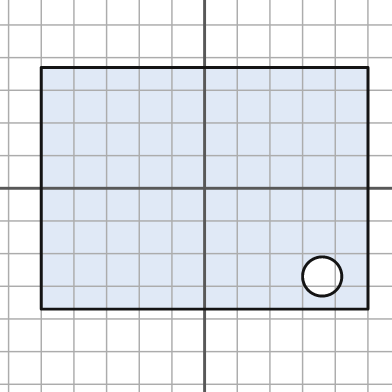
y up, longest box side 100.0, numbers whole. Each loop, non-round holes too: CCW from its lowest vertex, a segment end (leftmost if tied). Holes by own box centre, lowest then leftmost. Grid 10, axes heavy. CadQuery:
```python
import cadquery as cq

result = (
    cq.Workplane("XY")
    .moveTo(-50.0, -37.0)
    .lineTo(50.0, -37.0)
    .lineTo(50.0, 37.0)
    .lineTo(-50.0, 37.0)
    .close()
    .moveTo(36.0, -27.0)
    .circle(6.0)
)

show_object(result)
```